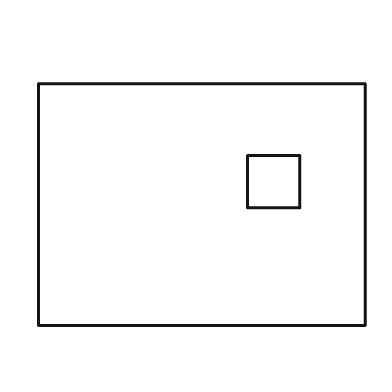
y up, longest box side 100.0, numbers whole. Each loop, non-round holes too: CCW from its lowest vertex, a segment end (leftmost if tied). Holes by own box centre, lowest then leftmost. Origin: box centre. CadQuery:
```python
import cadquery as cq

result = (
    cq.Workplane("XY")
    .moveTo(-50.0, -37.0)
    .lineTo(50.0, -37.0)
    .lineTo(50.0, 37.0)
    .lineTo(-50.0, 37.0)
    .close()
    .moveTo(14.0, -1.0)
    .lineTo(30.0, -1.0)
    .lineTo(30.0, 15.0)
    .lineTo(14.0, 15.0)
    .close()
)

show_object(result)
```